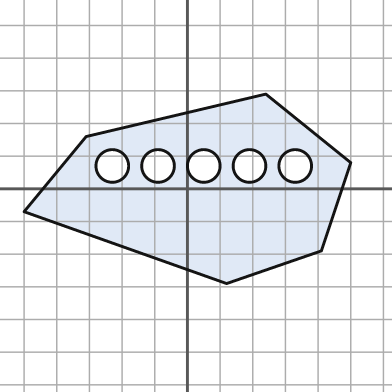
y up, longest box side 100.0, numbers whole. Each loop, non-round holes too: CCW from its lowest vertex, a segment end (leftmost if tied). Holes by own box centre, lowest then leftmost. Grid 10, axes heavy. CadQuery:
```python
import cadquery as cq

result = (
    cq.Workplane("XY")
    .moveTo(12.0, -29.0)
    .lineTo(41.0, -19.0)
    .lineTo(50.0, 8.0)
    .lineTo(24.0, 29.0)
    .lineTo(-31.0, 16.0)
    .lineTo(-50.0, -7.0)
    .close()
    .moveTo(-23.0, 7.0)
    .circle(5.0)
    .moveTo(-9.0, 7.0)
    .circle(5.0)
    .moveTo(5.0, 7.0)
    .circle(5.0)
    .moveTo(19.0, 7.0)
    .circle(5.0)
    .moveTo(33.0, 7.0)
    .circle(5.0)
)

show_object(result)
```